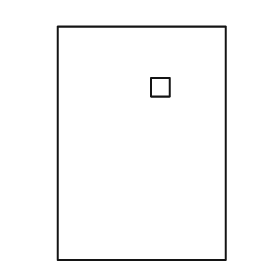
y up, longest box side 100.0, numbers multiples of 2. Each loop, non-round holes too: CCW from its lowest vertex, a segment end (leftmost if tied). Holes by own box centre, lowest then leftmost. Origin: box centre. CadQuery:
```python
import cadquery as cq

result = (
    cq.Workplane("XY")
    .moveTo(-36.0, -50.0)
    .lineTo(36.0, -50.0)
    .lineTo(36.0, 50.0)
    .lineTo(-36.0, 50.0)
    .close()
    .moveTo(4.0, 20.0)
    .lineTo(12.0, 20.0)
    .lineTo(12.0, 28.0)
    .lineTo(4.0, 28.0)
    .close()
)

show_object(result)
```